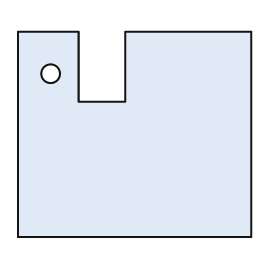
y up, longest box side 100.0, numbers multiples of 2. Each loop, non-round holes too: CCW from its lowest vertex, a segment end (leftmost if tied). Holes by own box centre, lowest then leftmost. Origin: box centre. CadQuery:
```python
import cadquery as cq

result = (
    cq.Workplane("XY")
    .moveTo(-50.0, -44.0)
    .lineTo(50.0, -44.0)
    .lineTo(50.0, 44.0)
    .lineTo(-4.0, 44.0)
    .lineTo(-4.0, 14.0)
    .lineTo(-24.0, 14.0)
    .lineTo(-24.0, 44.0)
    .lineTo(-50.0, 44.0)
    .close()
    .moveTo(-36.0, 26.0)
    .circle(4.0)
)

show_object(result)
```